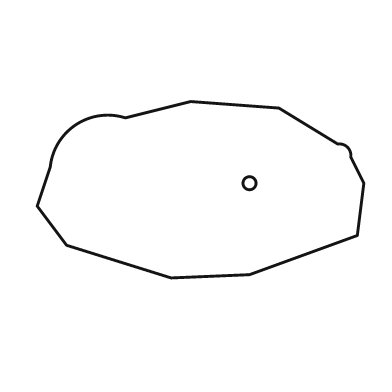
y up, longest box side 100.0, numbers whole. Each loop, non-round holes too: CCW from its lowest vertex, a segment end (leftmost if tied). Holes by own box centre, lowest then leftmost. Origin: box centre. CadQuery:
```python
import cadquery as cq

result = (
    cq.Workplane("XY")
    .moveTo(-9.0, -27.0)
    .lineTo(15.0, -26.0)
    .lineTo(48.0, -14.0)
    .lineTo(50.0, 2.0)
    .lineTo(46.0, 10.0)
    .threePointArc((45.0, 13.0), (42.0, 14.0))
    .lineTo(24.0, 25.0)
    .lineTo(-3.0, 27.0)
    .lineTo(-23.0, 22.0)
    .threePointArc((-38.0, 20.0), (-46.0, 7.0))
    .lineTo(-50.0, -5.0)
    .lineTo(-41.0, -17.0)
    .close()
    .moveTo(15.0, 2.0)
    .circle(2.0)
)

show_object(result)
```